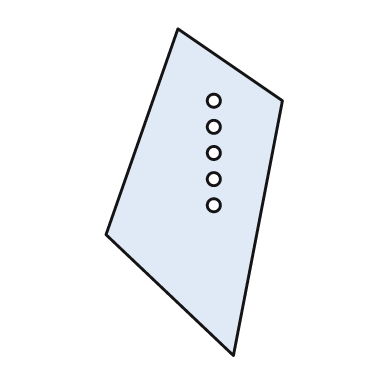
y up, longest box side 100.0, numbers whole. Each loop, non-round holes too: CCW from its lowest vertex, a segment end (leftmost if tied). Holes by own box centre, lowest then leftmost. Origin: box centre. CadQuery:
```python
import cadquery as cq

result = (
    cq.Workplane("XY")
    .moveTo(12.0, -50.0)
    .lineTo(27.0, 28.0)
    .lineTo(-5.0, 50.0)
    .lineTo(-27.0, -13.0)
    .close()
    .moveTo(6.0, -4.0)
    .circle(2.0)
    .moveTo(6.0, 4.0)
    .circle(2.0)
    .moveTo(6.0, 12.0)
    .circle(2.0)
    .moveTo(6.0, 20.0)
    .circle(2.0)
    .moveTo(6.0, 28.0)
    .circle(2.0)
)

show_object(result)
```